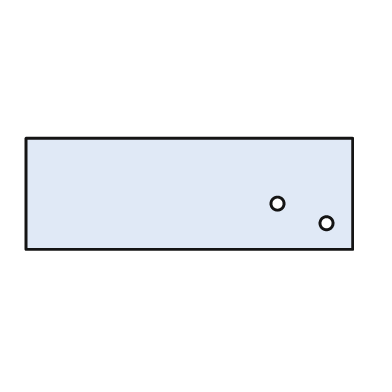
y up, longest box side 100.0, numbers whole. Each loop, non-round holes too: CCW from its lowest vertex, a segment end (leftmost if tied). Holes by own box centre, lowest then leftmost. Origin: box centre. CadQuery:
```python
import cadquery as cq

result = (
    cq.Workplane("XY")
    .moveTo(-50.0, -17.0)
    .lineTo(50.0, -17.0)
    .lineTo(50.0, 17.0)
    .lineTo(-50.0, 17.0)
    .close()
    .moveTo(42.0, -9.0)
    .circle(2.0)
    .moveTo(27.0, -3.0)
    .circle(2.0)
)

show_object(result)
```